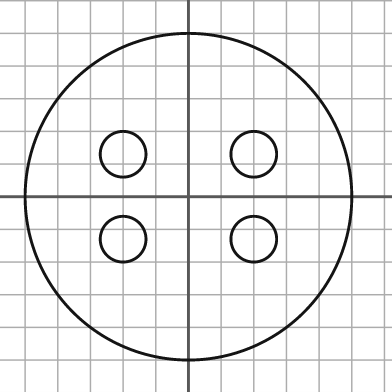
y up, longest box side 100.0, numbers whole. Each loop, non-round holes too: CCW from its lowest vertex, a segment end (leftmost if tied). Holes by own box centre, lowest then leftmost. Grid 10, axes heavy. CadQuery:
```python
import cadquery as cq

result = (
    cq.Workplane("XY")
    .moveTo(0.0, 0.0)
    .circle(50.0)
    .moveTo(-20.0, -13.0)
    .circle(7.0)
    .moveTo(20.0, -13.0)
    .circle(7.0)
    .moveTo(-20.0, 13.0)
    .circle(7.0)
    .moveTo(20.0, 13.0)
    .circle(7.0)
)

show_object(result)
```